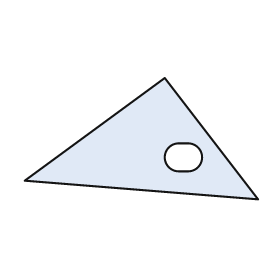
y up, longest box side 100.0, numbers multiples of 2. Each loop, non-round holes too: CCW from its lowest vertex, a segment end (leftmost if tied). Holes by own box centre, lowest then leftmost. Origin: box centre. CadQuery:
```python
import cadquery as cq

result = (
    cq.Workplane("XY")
    .moveTo(50.0, -26.0)
    .lineTo(10.0, 26.0)
    .lineTo(-50.0, -18.0)
    .close()
    .moveTo(16.0, -14.0)
    .lineTo(20.0, -14.0)
    .threePointArc((26.0, -8.0), (20.0, -2.0))
    .lineTo(16.0, -2.0)
    .threePointArc((10.0, -8.0), (16.0, -14.0))
    .close()
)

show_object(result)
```